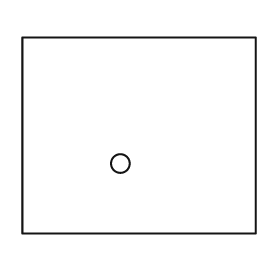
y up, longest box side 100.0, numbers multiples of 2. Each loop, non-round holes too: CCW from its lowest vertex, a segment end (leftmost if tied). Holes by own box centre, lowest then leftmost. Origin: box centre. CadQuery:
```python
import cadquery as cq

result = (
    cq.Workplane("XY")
    .moveTo(-50.0, -42.0)
    .lineTo(50.0, -42.0)
    .lineTo(50.0, 42.0)
    .lineTo(-50.0, 42.0)
    .close()
    .moveTo(-8.0, -12.0)
    .circle(4.0)
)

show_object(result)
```